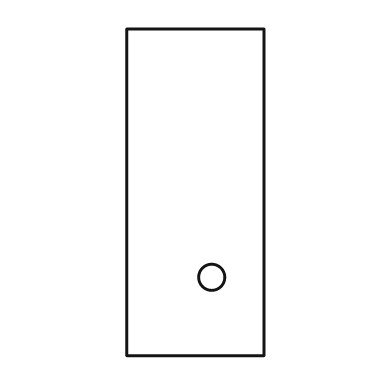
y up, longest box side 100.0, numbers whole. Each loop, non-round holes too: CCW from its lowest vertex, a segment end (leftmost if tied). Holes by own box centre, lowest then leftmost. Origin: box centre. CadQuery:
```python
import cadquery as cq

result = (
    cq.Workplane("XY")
    .moveTo(-21.0, -50.0)
    .lineTo(21.0, -50.0)
    .lineTo(21.0, 50.0)
    .lineTo(-21.0, 50.0)
    .close()
    .moveTo(5.0, -26.0)
    .circle(4.0)
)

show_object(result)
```